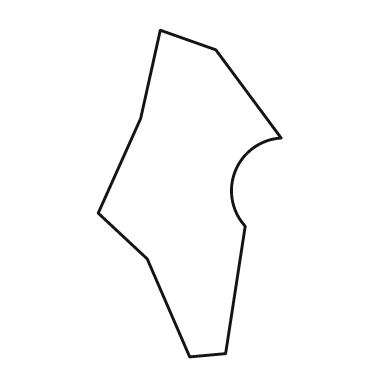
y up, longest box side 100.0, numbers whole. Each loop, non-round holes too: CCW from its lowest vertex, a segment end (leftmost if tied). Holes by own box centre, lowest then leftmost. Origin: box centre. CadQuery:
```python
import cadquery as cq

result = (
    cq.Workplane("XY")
    .moveTo(0.0, -50.0)
    .lineTo(11.0, -49.0)
    .lineTo(17.0, -10.0)
    .threePointArc((14.0, 7.0), (28.0, 17.0))
    .lineTo(8.0, 44.0)
    .lineTo(-9.0, 50.0)
    .lineTo(-15.0, 23.0)
    .lineTo(-28.0, -6.0)
    .lineTo(-13.0, -20.0)
    .close()
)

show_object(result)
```